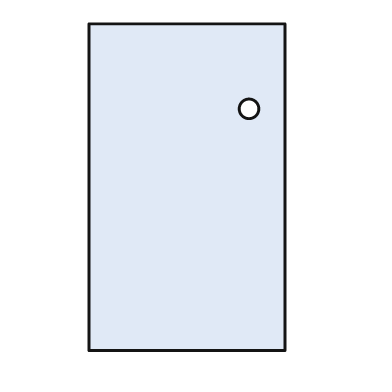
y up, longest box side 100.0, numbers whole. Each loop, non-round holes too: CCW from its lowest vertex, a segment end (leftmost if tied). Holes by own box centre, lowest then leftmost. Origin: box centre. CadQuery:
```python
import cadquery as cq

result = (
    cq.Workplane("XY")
    .moveTo(-30.0, -50.0)
    .lineTo(30.0, -50.0)
    .lineTo(30.0, 50.0)
    .lineTo(-30.0, 50.0)
    .close()
    .moveTo(19.0, 24.0)
    .circle(3.0)
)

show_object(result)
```